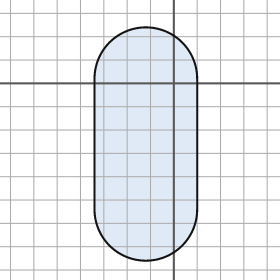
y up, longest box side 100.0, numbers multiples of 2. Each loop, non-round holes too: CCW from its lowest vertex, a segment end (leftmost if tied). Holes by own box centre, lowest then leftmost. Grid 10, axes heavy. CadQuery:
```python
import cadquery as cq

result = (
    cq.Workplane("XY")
    .moveTo(-34.0, -54.0)
    .threePointArc((-12.0, -76.0), (10.0, -54.0))
    .lineTo(10.0, 2.0)
    .threePointArc((-12.0, 24.0), (-34.0, 2.0))
    .close()
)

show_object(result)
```